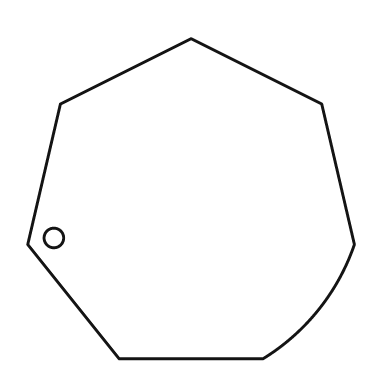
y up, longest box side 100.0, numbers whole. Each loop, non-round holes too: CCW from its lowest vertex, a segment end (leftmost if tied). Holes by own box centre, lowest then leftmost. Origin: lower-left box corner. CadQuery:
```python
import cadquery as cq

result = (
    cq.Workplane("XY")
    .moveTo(28.0, 0.0)
    .lineTo(72.0, 0.0)
    .threePointArc((89.0, 15.0), (100.0, 35.0))
    .lineTo(90.0, 78.0)
    .lineTo(50.0, 98.0)
    .lineTo(10.0, 78.0)
    .lineTo(0.0, 35.0)
    .close()
    .moveTo(8.0, 37.0)
    .circle(3.0)
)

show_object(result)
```